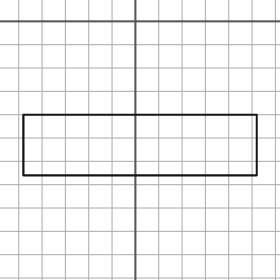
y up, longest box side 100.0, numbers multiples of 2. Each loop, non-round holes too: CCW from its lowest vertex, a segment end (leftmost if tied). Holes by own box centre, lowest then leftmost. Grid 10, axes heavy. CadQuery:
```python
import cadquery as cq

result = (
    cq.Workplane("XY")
    .moveTo(-48.0, -66.0)
    .lineTo(52.0, -66.0)
    .lineTo(52.0, -40.0)
    .lineTo(-48.0, -40.0)
    .close()
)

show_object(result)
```